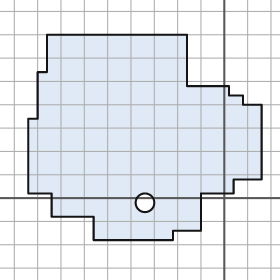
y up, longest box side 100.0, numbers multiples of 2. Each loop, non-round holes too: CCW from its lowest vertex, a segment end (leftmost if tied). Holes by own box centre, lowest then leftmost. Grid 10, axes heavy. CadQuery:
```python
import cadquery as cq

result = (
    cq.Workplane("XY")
    .moveTo(-56.0, -18.0)
    .lineTo(-22.0, -18.0)
    .lineTo(-22.0, -14.0)
    .lineTo(-10.0, -14.0)
    .lineTo(-10.0, 2.0)
    .lineTo(4.0, 2.0)
    .lineTo(4.0, 8.0)
    .lineTo(16.0, 8.0)
    .lineTo(16.0, 40.0)
    .lineTo(8.0, 40.0)
    .lineTo(8.0, 44.0)
    .lineTo(2.0, 44.0)
    .lineTo(2.0, 48.0)
    .lineTo(-16.0, 48.0)
    .lineTo(-16.0, 70.0)
    .lineTo(-76.0, 70.0)
    .lineTo(-76.0, 54.0)
    .lineTo(-80.0, 54.0)
    .lineTo(-80.0, 34.0)
    .lineTo(-84.0, 34.0)
    .lineTo(-84.0, 2.0)
    .lineTo(-74.0, 2.0)
    .lineTo(-74.0, -8.0)
    .lineTo(-56.0, -8.0)
    .close()
    .moveTo(-34.0, -2.0)
    .circle(4.0)
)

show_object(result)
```